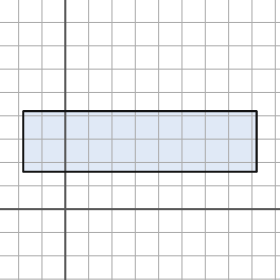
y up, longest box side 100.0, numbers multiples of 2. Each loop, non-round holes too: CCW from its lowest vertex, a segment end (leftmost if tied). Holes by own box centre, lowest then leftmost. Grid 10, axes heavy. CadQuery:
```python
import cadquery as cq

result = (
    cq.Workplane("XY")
    .moveTo(-18.0, 16.0)
    .lineTo(82.0, 16.0)
    .lineTo(82.0, 42.0)
    .lineTo(-18.0, 42.0)
    .close()
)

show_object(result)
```